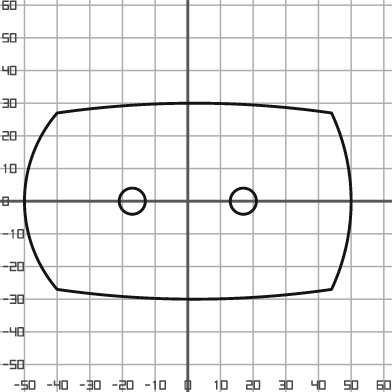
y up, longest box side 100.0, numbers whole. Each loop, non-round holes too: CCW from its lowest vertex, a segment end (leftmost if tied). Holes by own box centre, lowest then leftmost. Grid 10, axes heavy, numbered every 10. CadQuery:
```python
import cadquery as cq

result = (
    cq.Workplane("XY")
    .moveTo(-40.0, -27.0)
    .threePointArc((2.0, -30.0), (44.0, -27.0))
    .threePointArc((50.0, 0.0), (44.0, 27.0))
    .threePointArc((2.0, 30.0), (-40.0, 27.0))
    .threePointArc((-50.0, 0.0), (-40.0, -27.0))
    .close()
    .moveTo(-17.0, 0.0)
    .circle(4.0)
    .moveTo(17.0, 0.0)
    .circle(4.0)
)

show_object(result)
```